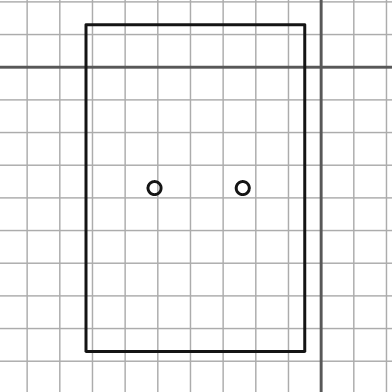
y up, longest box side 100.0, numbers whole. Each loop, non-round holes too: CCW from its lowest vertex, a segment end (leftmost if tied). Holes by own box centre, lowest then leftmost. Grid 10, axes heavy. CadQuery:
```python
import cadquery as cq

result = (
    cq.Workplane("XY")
    .moveTo(-72.0, -87.0)
    .lineTo(-5.0, -87.0)
    .lineTo(-5.0, 13.0)
    .lineTo(-72.0, 13.0)
    .close()
    .moveTo(-51.0, -37.0)
    .circle(2.0)
    .moveTo(-24.0, -37.0)
    .circle(2.0)
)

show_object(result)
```